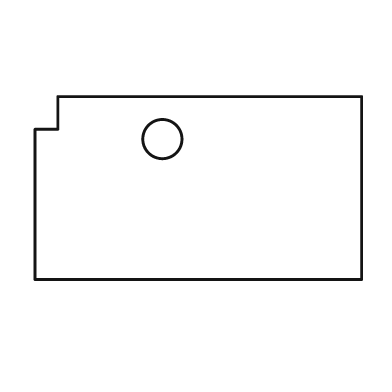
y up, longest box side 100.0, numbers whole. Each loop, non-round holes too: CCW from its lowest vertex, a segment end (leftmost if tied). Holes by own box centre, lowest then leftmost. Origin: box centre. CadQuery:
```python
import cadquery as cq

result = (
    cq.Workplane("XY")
    .moveTo(-50.0, -28.0)
    .lineTo(50.0, -28.0)
    .lineTo(50.0, 28.0)
    .lineTo(-43.0, 28.0)
    .lineTo(-43.0, 18.0)
    .lineTo(-50.0, 18.0)
    .close()
    .moveTo(-11.0, 15.0)
    .circle(6.0)
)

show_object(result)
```